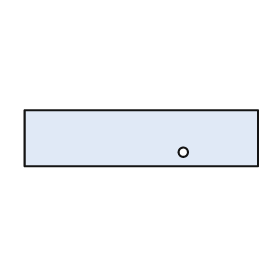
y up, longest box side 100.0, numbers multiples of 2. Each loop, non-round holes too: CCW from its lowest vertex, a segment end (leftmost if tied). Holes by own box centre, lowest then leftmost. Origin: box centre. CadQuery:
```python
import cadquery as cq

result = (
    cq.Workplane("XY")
    .moveTo(-50.0, -12.0)
    .lineTo(50.0, -12.0)
    .lineTo(50.0, 12.0)
    .lineTo(-50.0, 12.0)
    .close()
    .moveTo(18.0, -6.0)
    .circle(2.0)
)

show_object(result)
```